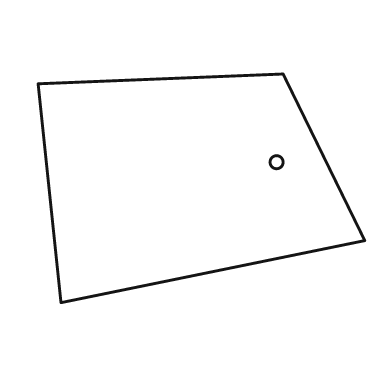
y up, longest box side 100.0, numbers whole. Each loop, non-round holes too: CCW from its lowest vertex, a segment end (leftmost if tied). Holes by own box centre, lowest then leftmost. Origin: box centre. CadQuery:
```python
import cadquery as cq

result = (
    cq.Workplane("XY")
    .moveTo(-43.0, -35.0)
    .lineTo(50.0, -16.0)
    .lineTo(25.0, 35.0)
    .lineTo(-50.0, 32.0)
    .close()
    .moveTo(23.0, 8.0)
    .circle(2.0)
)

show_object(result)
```